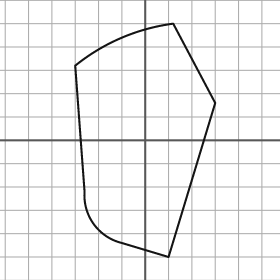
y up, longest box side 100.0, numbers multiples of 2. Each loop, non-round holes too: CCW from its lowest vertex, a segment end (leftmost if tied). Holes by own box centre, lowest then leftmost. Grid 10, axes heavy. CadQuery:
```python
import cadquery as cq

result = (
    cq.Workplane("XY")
    .moveTo(10.0, -50.0)
    .lineTo(30.0, 16.0)
    .lineTo(12.0, 50.0)
    .threePointArc((-10.0, 44.0), (-30.0, 32.0))
    .lineTo(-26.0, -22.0)
    .threePointArc((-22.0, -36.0), (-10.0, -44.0))
    .close()
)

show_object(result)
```